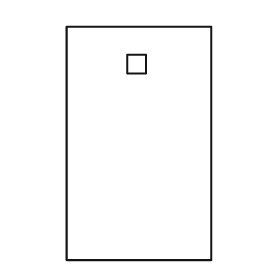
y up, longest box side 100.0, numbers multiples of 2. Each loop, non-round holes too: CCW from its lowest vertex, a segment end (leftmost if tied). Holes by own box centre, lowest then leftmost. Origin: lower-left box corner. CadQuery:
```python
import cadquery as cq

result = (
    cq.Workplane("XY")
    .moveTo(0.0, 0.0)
    .lineTo(62.0, 0.0)
    .lineTo(62.0, 100.0)
    .lineTo(0.0, 100.0)
    .close()
    .moveTo(26.0, 80.0)
    .lineTo(34.0, 80.0)
    .lineTo(34.0, 88.0)
    .lineTo(26.0, 88.0)
    .close()
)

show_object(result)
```